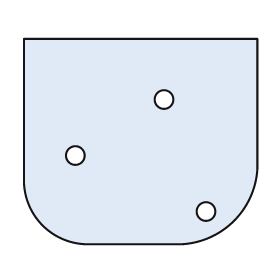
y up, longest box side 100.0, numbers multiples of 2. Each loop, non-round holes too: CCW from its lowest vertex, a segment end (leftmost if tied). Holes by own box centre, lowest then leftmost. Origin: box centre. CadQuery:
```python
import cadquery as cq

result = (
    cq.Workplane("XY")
    .moveTo(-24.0, -44.0)
    .lineTo(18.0, -44.0)
    .threePointArc((40.0, -34.0), (50.0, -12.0))
    .lineTo(50.0, 44.0)
    .lineTo(-50.0, 44.0)
    .lineTo(-50.0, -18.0)
    .threePointArc((-42.0, -36.0), (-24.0, -44.0))
    .close()
    .moveTo(28.0, -30.0)
    .circle(4.0)
    .moveTo(-28.0, -6.0)
    .circle(4.0)
    .moveTo(10.0, 18.0)
    .circle(4.0)
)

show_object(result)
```